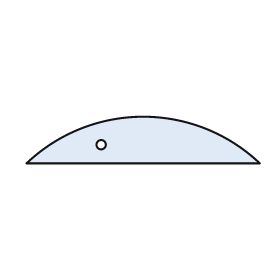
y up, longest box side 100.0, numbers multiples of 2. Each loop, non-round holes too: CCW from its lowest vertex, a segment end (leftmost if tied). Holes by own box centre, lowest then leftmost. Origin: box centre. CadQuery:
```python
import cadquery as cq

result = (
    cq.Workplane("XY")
    .moveTo(-50.0, -10.0)
    .lineTo(50.0, -10.0)
    .threePointArc((0.0, 10.0), (-50.0, -10.0))
    .close()
    .moveTo(-18.0, -2.0)
    .circle(2.0)
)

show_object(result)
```